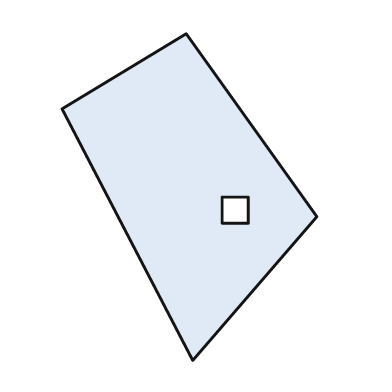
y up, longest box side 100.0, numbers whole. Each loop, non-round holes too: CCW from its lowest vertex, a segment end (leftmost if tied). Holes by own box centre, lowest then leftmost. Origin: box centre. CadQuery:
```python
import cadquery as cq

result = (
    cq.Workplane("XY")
    .moveTo(1.0, -50.0)
    .lineTo(39.0, -6.0)
    .lineTo(-1.0, 50.0)
    .lineTo(-39.0, 27.0)
    .close()
    .moveTo(10.0, -8.0)
    .lineTo(18.0, -8.0)
    .lineTo(18.0, 0.0)
    .lineTo(10.0, 0.0)
    .close()
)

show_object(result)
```